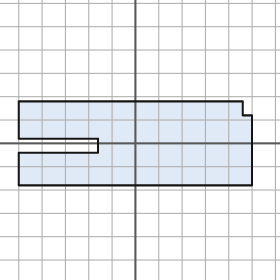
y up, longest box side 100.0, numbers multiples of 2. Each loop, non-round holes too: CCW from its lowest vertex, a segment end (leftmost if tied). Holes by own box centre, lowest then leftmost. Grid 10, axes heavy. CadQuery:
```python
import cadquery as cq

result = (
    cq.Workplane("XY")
    .moveTo(-50.0, -18.0)
    .lineTo(50.0, -18.0)
    .lineTo(50.0, 12.0)
    .lineTo(46.0, 12.0)
    .lineTo(46.0, 18.0)
    .lineTo(-50.0, 18.0)
    .lineTo(-50.0, 2.0)
    .lineTo(-16.0, 2.0)
    .lineTo(-16.0, -4.0)
    .lineTo(-50.0, -4.0)
    .close()
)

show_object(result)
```